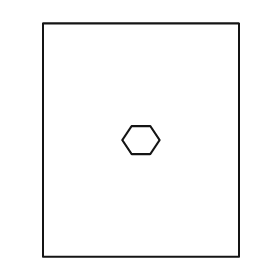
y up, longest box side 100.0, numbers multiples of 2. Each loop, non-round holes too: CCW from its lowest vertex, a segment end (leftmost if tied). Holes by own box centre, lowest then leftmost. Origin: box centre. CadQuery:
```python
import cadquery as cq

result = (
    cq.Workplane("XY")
    .moveTo(-42.0, -50.0)
    .lineTo(42.0, -50.0)
    .lineTo(42.0, 50.0)
    .lineTo(-42.0, 50.0)
    .close()
    .moveTo(-4.0, -6.0)
    .lineTo(4.0, -6.0)
    .lineTo(8.0, 0.0)
    .lineTo(4.0, 6.0)
    .lineTo(-4.0, 6.0)
    .lineTo(-8.0, 0.0)
    .close()
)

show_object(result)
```